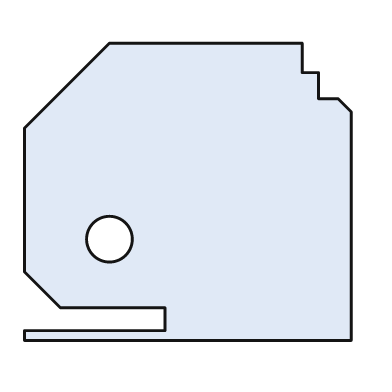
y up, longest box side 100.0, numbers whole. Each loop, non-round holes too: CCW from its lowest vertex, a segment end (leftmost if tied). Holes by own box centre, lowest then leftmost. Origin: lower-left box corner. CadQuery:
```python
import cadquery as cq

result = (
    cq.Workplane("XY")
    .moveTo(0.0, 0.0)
    .lineTo(100.0, 0.0)
    .lineTo(100.0, 70.0)
    .lineTo(96.0, 74.0)
    .lineTo(90.0, 74.0)
    .lineTo(90.0, 82.0)
    .lineTo(85.0, 82.0)
    .lineTo(85.0, 91.0)
    .lineTo(26.0, 91.0)
    .lineTo(0.0, 65.0)
    .lineTo(0.0, 21.0)
    .lineTo(11.0, 10.0)
    .lineTo(43.0, 10.0)
    .lineTo(43.0, 3.0)
    .lineTo(0.0, 3.0)
    .close()
    .moveTo(26.0, 31.0)
    .circle(7.0)
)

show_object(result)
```